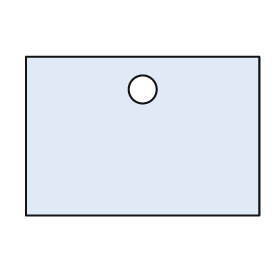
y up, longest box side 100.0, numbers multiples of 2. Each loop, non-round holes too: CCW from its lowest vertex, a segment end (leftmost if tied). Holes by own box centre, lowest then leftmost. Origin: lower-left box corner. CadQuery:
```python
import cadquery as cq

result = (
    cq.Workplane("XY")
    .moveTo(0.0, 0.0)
    .lineTo(100.0, 0.0)
    .lineTo(100.0, 68.0)
    .lineTo(0.0, 68.0)
    .close()
    .moveTo(50.0, 54.0)
    .circle(6.0)
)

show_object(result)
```